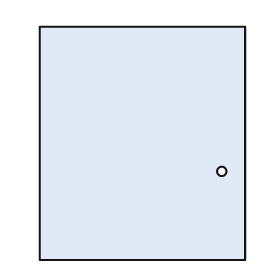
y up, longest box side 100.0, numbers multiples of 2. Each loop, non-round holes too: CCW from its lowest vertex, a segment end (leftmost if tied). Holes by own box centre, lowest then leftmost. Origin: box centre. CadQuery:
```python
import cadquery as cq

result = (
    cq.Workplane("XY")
    .moveTo(-44.0, -50.0)
    .lineTo(44.0, -50.0)
    .lineTo(44.0, 50.0)
    .lineTo(-44.0, 50.0)
    .close()
    .moveTo(34.0, -12.0)
    .circle(2.0)
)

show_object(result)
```